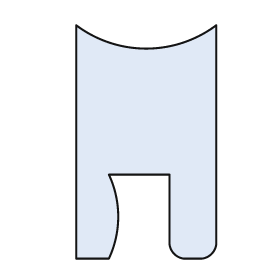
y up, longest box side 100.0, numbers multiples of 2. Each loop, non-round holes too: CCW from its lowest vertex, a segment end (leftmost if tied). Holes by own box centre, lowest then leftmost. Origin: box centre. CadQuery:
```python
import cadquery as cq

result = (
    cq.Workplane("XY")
    .moveTo(-30.0, -50.0)
    .lineTo(-16.0, -50.0)
    .threePointArc((-12.0, -32.0), (-16.0, -14.0))
    .lineTo(10.0, -14.0)
    .lineTo(10.0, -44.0)
    .threePointArc((12.0, -48.0), (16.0, -50.0))
    .lineTo(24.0, -50.0)
    .threePointArc((28.0, -48.0), (30.0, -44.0))
    .lineTo(30.0, 50.0)
    .threePointArc((0.0, 40.0), (-30.0, 50.0))
    .close()
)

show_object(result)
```